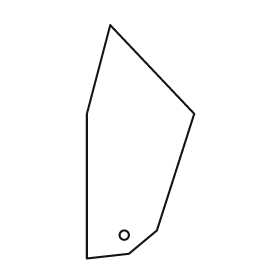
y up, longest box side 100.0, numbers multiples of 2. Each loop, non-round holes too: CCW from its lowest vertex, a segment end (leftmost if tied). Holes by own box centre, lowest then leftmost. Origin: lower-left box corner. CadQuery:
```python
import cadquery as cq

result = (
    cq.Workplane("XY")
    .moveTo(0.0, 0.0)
    .lineTo(18.0, 2.0)
    .lineTo(30.0, 12.0)
    .lineTo(46.0, 62.0)
    .lineTo(10.0, 100.0)
    .lineTo(0.0, 62.0)
    .close()
    .moveTo(16.0, 10.0)
    .circle(2.0)
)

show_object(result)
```